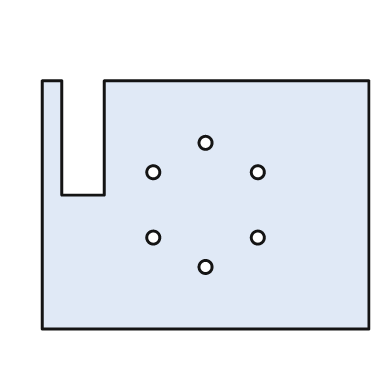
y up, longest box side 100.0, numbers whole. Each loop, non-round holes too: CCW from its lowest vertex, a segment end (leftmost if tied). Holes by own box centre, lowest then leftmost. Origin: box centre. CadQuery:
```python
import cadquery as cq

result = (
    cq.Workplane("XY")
    .moveTo(-50.0, -38.0)
    .lineTo(50.0, -38.0)
    .lineTo(50.0, 38.0)
    .lineTo(-31.0, 38.0)
    .lineTo(-31.0, 3.0)
    .lineTo(-44.0, 3.0)
    .lineTo(-44.0, 38.0)
    .lineTo(-50.0, 38.0)
    .close()
    .moveTo(0.0, -19.0)
    .circle(2.0)
    .moveTo(-16.0, -10.0)
    .circle(2.0)
    .moveTo(16.0, -10.0)
    .circle(2.0)
    .moveTo(-16.0, 10.0)
    .circle(2.0)
    .moveTo(16.0, 10.0)
    .circle(2.0)
    .moveTo(0.0, 19.0)
    .circle(2.0)
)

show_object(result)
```